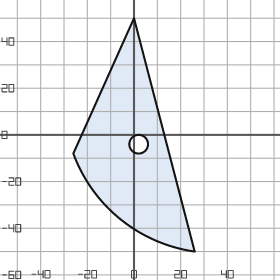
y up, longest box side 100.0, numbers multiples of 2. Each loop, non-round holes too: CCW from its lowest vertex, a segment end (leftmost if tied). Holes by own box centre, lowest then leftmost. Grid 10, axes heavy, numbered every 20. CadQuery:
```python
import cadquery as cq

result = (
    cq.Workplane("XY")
    .moveTo(26.0, -50.0)
    .lineTo(0.0, 50.0)
    .lineTo(-26.0, -8.0)
    .threePointArc((-6.0, -36.0), (26.0, -50.0))
    .close()
    .moveTo(2.0, -4.0)
    .circle(4.0)
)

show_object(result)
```